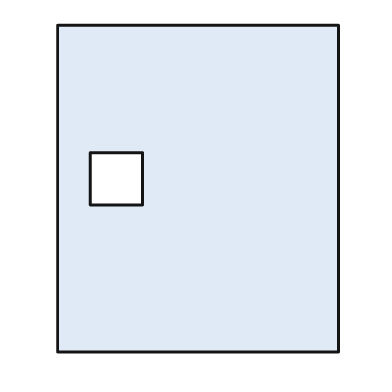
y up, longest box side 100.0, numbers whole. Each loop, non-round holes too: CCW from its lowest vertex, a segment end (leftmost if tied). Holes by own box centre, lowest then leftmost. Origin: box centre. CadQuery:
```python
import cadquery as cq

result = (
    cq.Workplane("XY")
    .moveTo(-43.0, -50.0)
    .lineTo(43.0, -50.0)
    .lineTo(43.0, 50.0)
    .lineTo(-43.0, 50.0)
    .close()
    .moveTo(-33.0, -5.0)
    .lineTo(-17.0, -5.0)
    .lineTo(-17.0, 11.0)
    .lineTo(-33.0, 11.0)
    .close()
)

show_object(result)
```